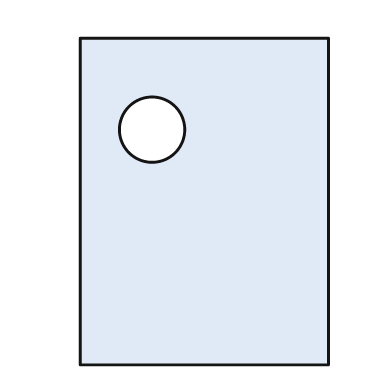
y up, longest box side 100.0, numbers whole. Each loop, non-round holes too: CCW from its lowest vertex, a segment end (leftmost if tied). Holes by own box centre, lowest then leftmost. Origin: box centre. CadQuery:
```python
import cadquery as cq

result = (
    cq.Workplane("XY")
    .moveTo(-38.0, -50.0)
    .lineTo(38.0, -50.0)
    .lineTo(38.0, 50.0)
    .lineTo(-38.0, 50.0)
    .close()
    .moveTo(-16.0, 22.0)
    .circle(10.0)
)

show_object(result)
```